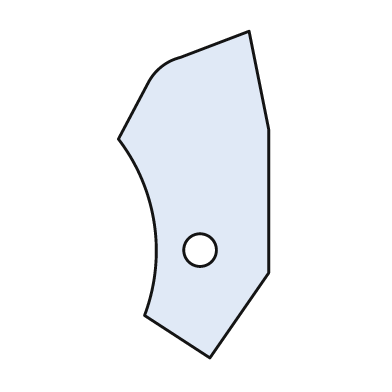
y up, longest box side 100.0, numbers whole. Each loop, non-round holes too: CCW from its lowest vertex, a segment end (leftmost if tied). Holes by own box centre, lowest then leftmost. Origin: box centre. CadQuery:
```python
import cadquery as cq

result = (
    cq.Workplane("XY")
    .moveTo(5.0, -50.0)
    .lineTo(23.0, -24.0)
    .lineTo(23.0, 20.0)
    .lineTo(17.0, 50.0)
    .lineTo(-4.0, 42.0)
    .threePointArc((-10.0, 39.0), (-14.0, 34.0))
    .lineTo(-23.0, 17.0)
    .threePointArc((-12.0, -9.0), (-15.0, -37.0))
    .close()
    .moveTo(2.0, -17.0)
    .circle(5.0)
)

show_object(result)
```